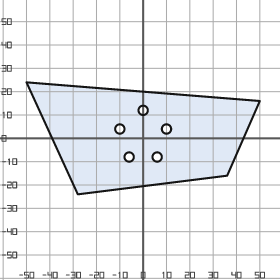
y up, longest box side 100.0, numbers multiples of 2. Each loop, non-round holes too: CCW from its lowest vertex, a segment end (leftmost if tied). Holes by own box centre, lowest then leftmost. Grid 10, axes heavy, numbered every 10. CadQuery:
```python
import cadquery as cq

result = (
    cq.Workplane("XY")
    .moveTo(-28.0, -24.0)
    .lineTo(36.0, -16.0)
    .lineTo(50.0, 16.0)
    .lineTo(-50.0, 24.0)
    .close()
    .moveTo(-6.0, -8.0)
    .circle(2.0)
    .moveTo(6.0, -8.0)
    .circle(2.0)
    .moveTo(-10.0, 4.0)
    .circle(2.0)
    .moveTo(10.0, 4.0)
    .circle(2.0)
    .moveTo(0.0, 12.0)
    .circle(2.0)
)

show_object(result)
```